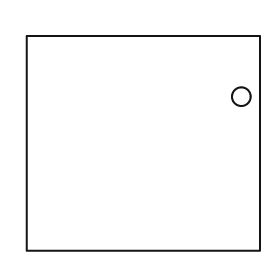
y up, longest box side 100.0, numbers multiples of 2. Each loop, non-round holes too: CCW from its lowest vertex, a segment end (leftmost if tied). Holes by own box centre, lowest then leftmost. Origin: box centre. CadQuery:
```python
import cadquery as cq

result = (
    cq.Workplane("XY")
    .moveTo(-50.0, -46.0)
    .lineTo(50.0, -46.0)
    .lineTo(50.0, 46.0)
    .lineTo(-50.0, 46.0)
    .close()
    .moveTo(42.0, 20.0)
    .circle(4.0)
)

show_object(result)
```